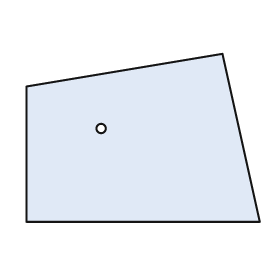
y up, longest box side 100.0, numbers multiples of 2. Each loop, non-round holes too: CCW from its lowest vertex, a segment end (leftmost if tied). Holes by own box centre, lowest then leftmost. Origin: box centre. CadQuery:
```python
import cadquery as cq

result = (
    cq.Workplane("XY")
    .moveTo(-50.0, -36.0)
    .lineTo(50.0, -36.0)
    .lineTo(34.0, 36.0)
    .lineTo(-50.0, 22.0)
    .close()
    .moveTo(-18.0, 4.0)
    .circle(2.0)
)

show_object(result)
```